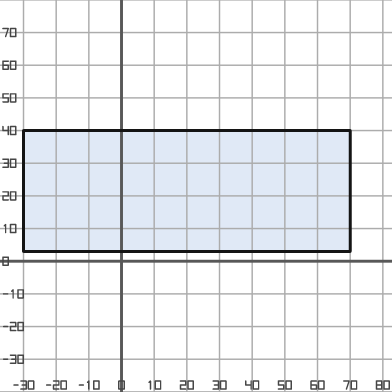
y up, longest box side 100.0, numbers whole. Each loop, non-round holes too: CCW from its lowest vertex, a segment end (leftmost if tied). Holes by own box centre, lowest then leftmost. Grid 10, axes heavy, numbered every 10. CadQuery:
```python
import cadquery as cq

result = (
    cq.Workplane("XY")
    .moveTo(-30.0, 3.0)
    .lineTo(70.0, 3.0)
    .lineTo(70.0, 40.0)
    .lineTo(-30.0, 40.0)
    .close()
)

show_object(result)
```